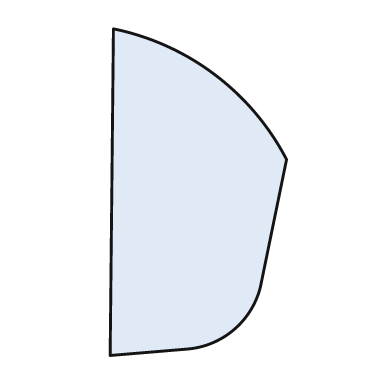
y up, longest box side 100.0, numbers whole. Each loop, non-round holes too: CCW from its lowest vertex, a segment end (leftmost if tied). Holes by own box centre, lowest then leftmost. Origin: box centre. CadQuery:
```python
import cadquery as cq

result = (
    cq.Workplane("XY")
    .moveTo(-27.0, -50.0)
    .lineTo(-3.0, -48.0)
    .threePointArc((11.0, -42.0), (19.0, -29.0))
    .lineTo(27.0, 10.0)
    .threePointArc((5.0, 36.0), (-26.0, 50.0))
    .close()
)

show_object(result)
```